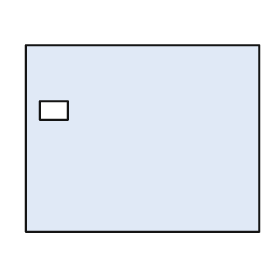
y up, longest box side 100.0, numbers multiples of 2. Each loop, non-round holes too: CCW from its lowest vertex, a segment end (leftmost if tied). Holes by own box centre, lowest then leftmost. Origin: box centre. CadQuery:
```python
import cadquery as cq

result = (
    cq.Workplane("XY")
    .moveTo(-50.0, -40.0)
    .lineTo(50.0, -40.0)
    .lineTo(50.0, 40.0)
    .lineTo(-50.0, 40.0)
    .close()
    .moveTo(-44.0, 8.0)
    .lineTo(-32.0, 8.0)
    .lineTo(-32.0, 16.0)
    .lineTo(-44.0, 16.0)
    .close()
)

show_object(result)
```